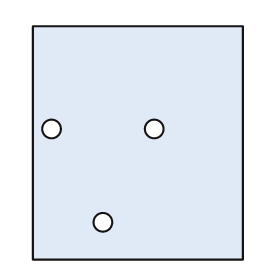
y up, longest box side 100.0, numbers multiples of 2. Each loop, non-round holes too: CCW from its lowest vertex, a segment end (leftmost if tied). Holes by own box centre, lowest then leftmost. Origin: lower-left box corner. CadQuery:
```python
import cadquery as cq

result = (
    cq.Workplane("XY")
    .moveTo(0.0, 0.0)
    .lineTo(90.0, 0.0)
    .lineTo(90.0, 100.0)
    .lineTo(0.0, 100.0)
    .close()
    .moveTo(30.0, 16.0)
    .circle(4.0)
    .moveTo(8.0, 56.0)
    .circle(4.0)
    .moveTo(52.0, 56.0)
    .circle(4.0)
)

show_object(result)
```